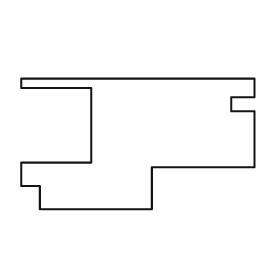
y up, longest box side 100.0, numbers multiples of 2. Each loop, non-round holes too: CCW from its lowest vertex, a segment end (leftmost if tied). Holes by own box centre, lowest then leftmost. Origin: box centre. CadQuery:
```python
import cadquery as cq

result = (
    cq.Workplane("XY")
    .moveTo(-42.0, -28.0)
    .lineTo(6.0, -28.0)
    .lineTo(6.0, -10.0)
    .lineTo(50.0, -10.0)
    .lineTo(50.0, 14.0)
    .lineTo(40.0, 14.0)
    .lineTo(40.0, 20.0)
    .lineTo(50.0, 20.0)
    .lineTo(50.0, 28.0)
    .lineTo(-50.0, 28.0)
    .lineTo(-50.0, 24.0)
    .lineTo(-20.0, 24.0)
    .lineTo(-20.0, -8.0)
    .lineTo(-50.0, -8.0)
    .lineTo(-50.0, -18.0)
    .lineTo(-42.0, -18.0)
    .close()
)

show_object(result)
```